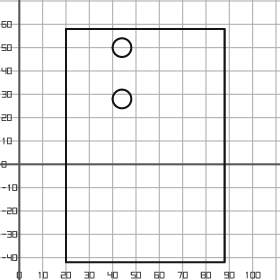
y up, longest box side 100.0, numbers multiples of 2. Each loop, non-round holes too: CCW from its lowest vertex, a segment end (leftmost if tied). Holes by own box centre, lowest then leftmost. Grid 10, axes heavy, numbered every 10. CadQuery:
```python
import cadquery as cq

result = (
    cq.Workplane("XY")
    .moveTo(20.0, -42.0)
    .lineTo(88.0, -42.0)
    .lineTo(88.0, 58.0)
    .lineTo(20.0, 58.0)
    .close()
    .moveTo(44.0, 28.0)
    .circle(4.0)
    .moveTo(44.0, 50.0)
    .circle(4.0)
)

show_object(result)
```